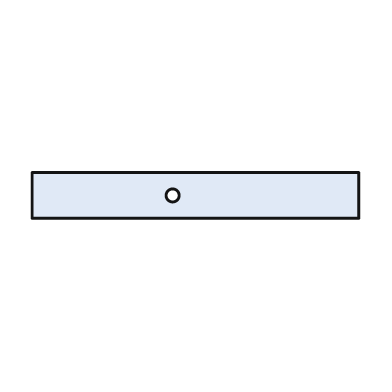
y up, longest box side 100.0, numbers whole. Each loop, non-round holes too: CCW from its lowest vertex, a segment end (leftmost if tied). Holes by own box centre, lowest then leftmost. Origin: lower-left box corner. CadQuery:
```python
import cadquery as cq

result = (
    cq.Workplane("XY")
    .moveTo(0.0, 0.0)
    .lineTo(100.0, 0.0)
    .lineTo(100.0, 14.0)
    .lineTo(0.0, 14.0)
    .close()
    .moveTo(43.0, 7.0)
    .circle(2.0)
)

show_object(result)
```